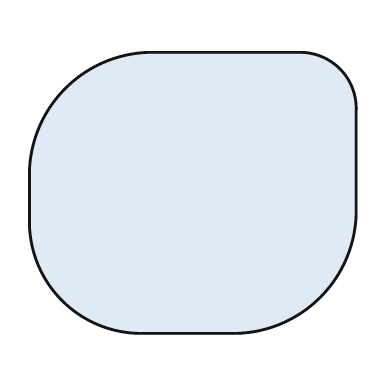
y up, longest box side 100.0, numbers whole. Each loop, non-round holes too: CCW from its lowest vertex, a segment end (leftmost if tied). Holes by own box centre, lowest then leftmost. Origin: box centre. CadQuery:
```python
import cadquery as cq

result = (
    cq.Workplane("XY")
    .moveTo(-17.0, -43.0)
    .lineTo(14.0, -43.0)
    .threePointArc((39.0, -32.0), (50.0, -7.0))
    .lineTo(50.0, 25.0)
    .threePointArc((45.0, 38.0), (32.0, 43.0))
    .lineTo(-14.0, 43.0)
    .threePointArc((-39.0, 32.0), (-50.0, 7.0))
    .lineTo(-50.0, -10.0)
    .threePointArc((-40.0, -33.0), (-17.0, -43.0))
    .close()
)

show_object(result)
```